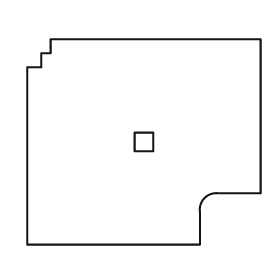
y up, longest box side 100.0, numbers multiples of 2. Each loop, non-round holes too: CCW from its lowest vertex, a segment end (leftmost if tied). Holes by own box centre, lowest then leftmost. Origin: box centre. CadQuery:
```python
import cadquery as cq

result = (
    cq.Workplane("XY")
    .moveTo(-50.0, -44.0)
    .lineTo(24.0, -44.0)
    .lineTo(24.0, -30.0)
    .threePointArc((26.0, -24.0), (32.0, -22.0))
    .lineTo(50.0, -22.0)
    .lineTo(50.0, 44.0)
    .lineTo(-40.0, 44.0)
    .lineTo(-40.0, 38.0)
    .lineTo(-44.0, 38.0)
    .lineTo(-44.0, 32.0)
    .lineTo(-50.0, 32.0)
    .close()
    .moveTo(-4.0, -4.0)
    .lineTo(4.0, -4.0)
    .lineTo(4.0, 4.0)
    .lineTo(-4.0, 4.0)
    .close()
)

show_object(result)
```